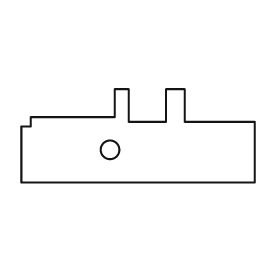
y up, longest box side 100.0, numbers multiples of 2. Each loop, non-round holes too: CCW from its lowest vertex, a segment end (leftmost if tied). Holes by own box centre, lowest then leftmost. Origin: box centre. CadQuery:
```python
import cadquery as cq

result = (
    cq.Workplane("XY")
    .moveTo(-50.0, -20.0)
    .lineTo(50.0, -20.0)
    .lineTo(50.0, 6.0)
    .lineTo(20.0, 6.0)
    .lineTo(20.0, 20.0)
    .lineTo(12.0, 20.0)
    .lineTo(12.0, 6.0)
    .lineTo(-4.0, 6.0)
    .lineTo(-4.0, 20.0)
    .lineTo(-10.0, 20.0)
    .lineTo(-10.0, 8.0)
    .lineTo(-46.0, 8.0)
    .lineTo(-46.0, 4.0)
    .lineTo(-50.0, 4.0)
    .close()
    .moveTo(-12.0, -6.0)
    .circle(4.0)
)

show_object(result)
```